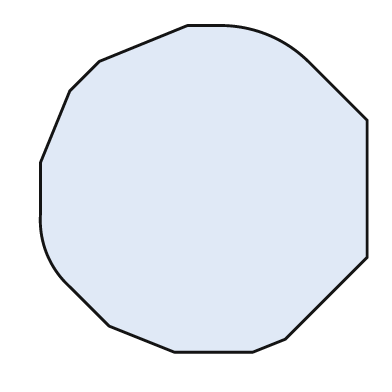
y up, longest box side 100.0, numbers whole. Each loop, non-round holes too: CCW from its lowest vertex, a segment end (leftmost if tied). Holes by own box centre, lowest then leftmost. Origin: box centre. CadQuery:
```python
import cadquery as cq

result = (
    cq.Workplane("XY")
    .moveTo(-9.0, -50.0)
    .lineTo(15.0, -50.0)
    .lineTo(25.0, -46.0)
    .lineTo(50.0, -21.0)
    .lineTo(50.0, 21.0)
    .lineTo(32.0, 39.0)
    .threePointArc((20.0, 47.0), (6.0, 50.0))
    .lineTo(-5.0, 50.0)
    .lineTo(-32.0, 39.0)
    .lineTo(-41.0, 30.0)
    .lineTo(-50.0, 8.0)
    .lineTo(-50.0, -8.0)
    .threePointArc((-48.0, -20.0), (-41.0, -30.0))
    .lineTo(-29.0, -42.0)
    .close()
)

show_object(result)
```